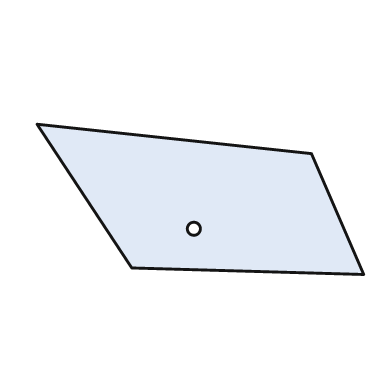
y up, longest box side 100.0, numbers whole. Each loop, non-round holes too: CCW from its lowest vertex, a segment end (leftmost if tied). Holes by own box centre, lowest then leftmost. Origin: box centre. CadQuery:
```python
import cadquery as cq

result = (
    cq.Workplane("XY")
    .moveTo(50.0, -23.0)
    .lineTo(34.0, 14.0)
    .lineTo(-50.0, 23.0)
    .lineTo(-21.0, -21.0)
    .close()
    .moveTo(-2.0, -9.0)
    .circle(2.0)
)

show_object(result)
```